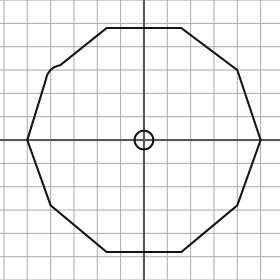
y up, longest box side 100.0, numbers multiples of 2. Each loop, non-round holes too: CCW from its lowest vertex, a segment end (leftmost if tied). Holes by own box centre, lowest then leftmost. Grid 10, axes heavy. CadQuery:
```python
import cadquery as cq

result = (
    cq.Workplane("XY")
    .moveTo(-16.0, -48.0)
    .lineTo(16.0, -48.0)
    .lineTo(40.0, -28.0)
    .lineTo(50.0, 0.0)
    .lineTo(40.0, 30.0)
    .lineTo(16.0, 48.0)
    .lineTo(-16.0, 48.0)
    .lineTo(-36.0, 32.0)
    .threePointArc((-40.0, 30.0), (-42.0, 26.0))
    .lineTo(-50.0, 0.0)
    .lineTo(-40.0, -28.0)
    .close()
    .moveTo(0.0, 0.0)
    .circle(4.0)
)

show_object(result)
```